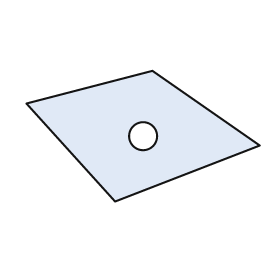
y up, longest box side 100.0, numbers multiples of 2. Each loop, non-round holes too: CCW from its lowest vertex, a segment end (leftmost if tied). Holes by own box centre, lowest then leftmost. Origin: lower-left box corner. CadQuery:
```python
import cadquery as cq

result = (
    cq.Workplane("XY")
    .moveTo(38.0, 0.0)
    .lineTo(100.0, 24.0)
    .lineTo(54.0, 56.0)
    .lineTo(0.0, 42.0)
    .close()
    .moveTo(50.0, 28.0)
    .circle(6.0)
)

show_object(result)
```